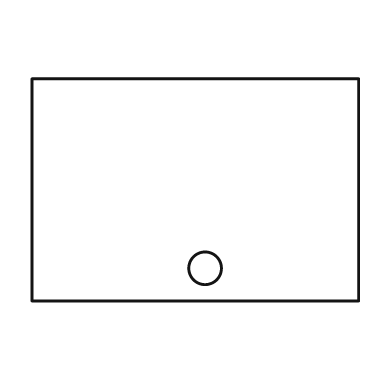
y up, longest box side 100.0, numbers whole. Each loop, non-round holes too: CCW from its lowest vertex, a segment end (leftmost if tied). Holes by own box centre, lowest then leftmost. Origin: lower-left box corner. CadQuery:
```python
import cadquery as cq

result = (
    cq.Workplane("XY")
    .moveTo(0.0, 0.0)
    .lineTo(100.0, 0.0)
    .lineTo(100.0, 68.0)
    .lineTo(0.0, 68.0)
    .close()
    .moveTo(53.0, 10.0)
    .circle(5.0)
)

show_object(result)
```